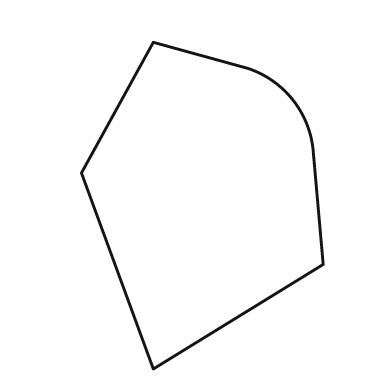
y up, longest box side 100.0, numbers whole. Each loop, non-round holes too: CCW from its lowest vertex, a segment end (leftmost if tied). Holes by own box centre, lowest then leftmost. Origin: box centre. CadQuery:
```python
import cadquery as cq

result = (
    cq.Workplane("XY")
    .moveTo(-15.0, -50.0)
    .lineTo(37.0, -18.0)
    .lineTo(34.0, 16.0)
    .threePointArc((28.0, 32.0), (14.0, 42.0))
    .lineTo(-15.0, 50.0)
    .lineTo(-37.0, 10.0)
    .close()
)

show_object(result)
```